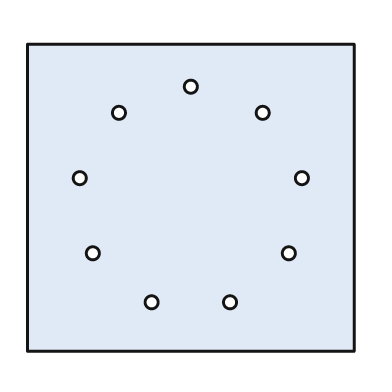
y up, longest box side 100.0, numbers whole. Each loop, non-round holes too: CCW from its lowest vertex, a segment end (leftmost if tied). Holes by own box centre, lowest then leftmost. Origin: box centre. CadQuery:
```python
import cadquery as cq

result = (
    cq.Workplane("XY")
    .moveTo(-50.0, -47.0)
    .lineTo(50.0, -47.0)
    .lineTo(50.0, 47.0)
    .lineTo(-50.0, 47.0)
    .close()
    .moveTo(-12.0, -32.0)
    .circle(2.0)
    .moveTo(12.0, -32.0)
    .circle(2.0)
    .moveTo(-30.0, -17.0)
    .circle(2.0)
    .moveTo(30.0, -17.0)
    .circle(2.0)
    .moveTo(-34.0, 6.0)
    .circle(2.0)
    .moveTo(34.0, 6.0)
    .circle(2.0)
    .moveTo(-22.0, 26.0)
    .circle(2.0)
    .moveTo(22.0, 26.0)
    .circle(2.0)
    .moveTo(0.0, 34.0)
    .circle(2.0)
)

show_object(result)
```